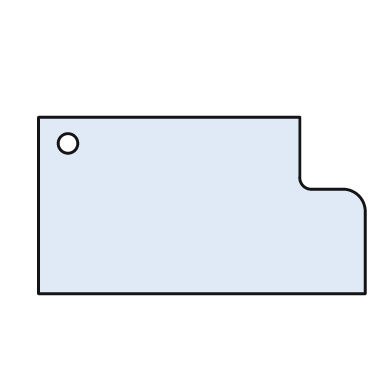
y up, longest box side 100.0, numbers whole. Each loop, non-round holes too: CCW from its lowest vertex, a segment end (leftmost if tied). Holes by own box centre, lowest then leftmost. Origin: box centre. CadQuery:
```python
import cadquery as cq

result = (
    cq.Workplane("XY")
    .moveTo(-50.0, -27.0)
    .lineTo(50.0, -27.0)
    .lineTo(50.0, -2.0)
    .threePointArc((48.0, 3.0), (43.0, 5.0))
    .lineTo(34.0, 5.0)
    .threePointArc((31.0, 6.0), (30.0, 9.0))
    .lineTo(30.0, 27.0)
    .lineTo(-50.0, 27.0)
    .close()
    .moveTo(-41.0, 19.0)
    .circle(3.0)
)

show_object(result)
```